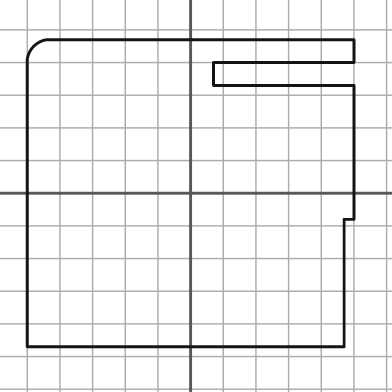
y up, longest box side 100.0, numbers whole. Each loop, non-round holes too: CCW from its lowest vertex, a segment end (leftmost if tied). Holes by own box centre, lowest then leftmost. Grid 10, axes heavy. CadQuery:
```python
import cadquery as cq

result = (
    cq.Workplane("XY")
    .moveTo(-50.0, -47.0)
    .lineTo(47.0, -47.0)
    .lineTo(47.0, -8.0)
    .lineTo(50.0, -8.0)
    .lineTo(50.0, 33.0)
    .lineTo(7.0, 33.0)
    .lineTo(7.0, 40.0)
    .lineTo(50.0, 40.0)
    .lineTo(50.0, 47.0)
    .lineTo(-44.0, 47.0)
    .threePointArc((-48.0, 45.0), (-50.0, 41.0))
    .close()
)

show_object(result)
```